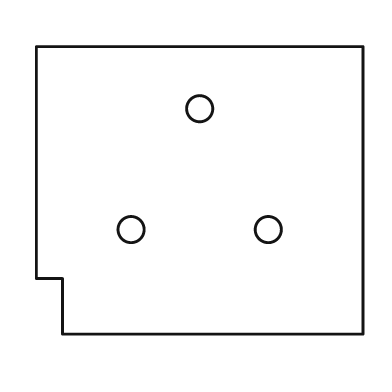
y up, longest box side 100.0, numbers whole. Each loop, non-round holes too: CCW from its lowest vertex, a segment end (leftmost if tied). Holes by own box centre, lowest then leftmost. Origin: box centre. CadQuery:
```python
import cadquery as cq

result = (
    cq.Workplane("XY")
    .moveTo(-42.0, -44.0)
    .lineTo(50.0, -44.0)
    .lineTo(50.0, 44.0)
    .lineTo(-50.0, 44.0)
    .lineTo(-50.0, -27.0)
    .lineTo(-42.0, -27.0)
    .close()
    .moveTo(-21.0, -12.0)
    .circle(4.0)
    .moveTo(21.0, -12.0)
    .circle(4.0)
    .moveTo(0.0, 25.0)
    .circle(4.0)
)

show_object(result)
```